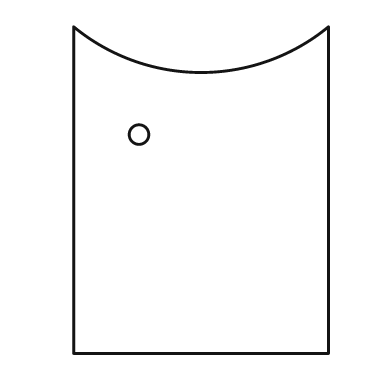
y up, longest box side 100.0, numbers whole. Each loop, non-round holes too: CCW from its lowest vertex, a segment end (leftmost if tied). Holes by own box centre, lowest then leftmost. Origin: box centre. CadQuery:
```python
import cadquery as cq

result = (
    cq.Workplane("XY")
    .moveTo(-39.0, -50.0)
    .lineTo(39.0, -50.0)
    .lineTo(39.0, 50.0)
    .threePointArc((0.0, 36.0), (-39.0, 50.0))
    .close()
    .moveTo(-19.0, 17.0)
    .circle(3.0)
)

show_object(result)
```